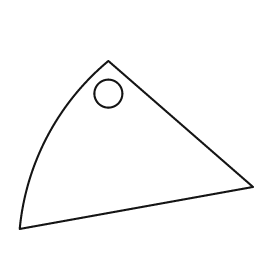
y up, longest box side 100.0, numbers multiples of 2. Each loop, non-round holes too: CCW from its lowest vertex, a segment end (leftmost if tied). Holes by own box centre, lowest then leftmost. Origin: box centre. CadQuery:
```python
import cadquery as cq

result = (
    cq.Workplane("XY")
    .moveTo(-50.0, -36.0)
    .lineTo(50.0, -18.0)
    .lineTo(-12.0, 36.0)
    .threePointArc((-38.0, 4.0), (-50.0, -36.0))
    .close()
    .moveTo(-12.0, 22.0)
    .circle(6.0)
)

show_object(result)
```